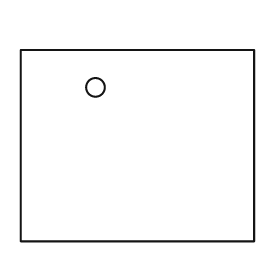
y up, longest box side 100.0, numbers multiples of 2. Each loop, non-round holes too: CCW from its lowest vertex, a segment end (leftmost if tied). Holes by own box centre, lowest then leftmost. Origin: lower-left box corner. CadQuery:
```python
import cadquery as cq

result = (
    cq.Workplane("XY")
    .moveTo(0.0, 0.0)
    .lineTo(100.0, 0.0)
    .lineTo(100.0, 82.0)
    .lineTo(0.0, 82.0)
    .close()
    .moveTo(32.0, 66.0)
    .circle(4.0)
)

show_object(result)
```